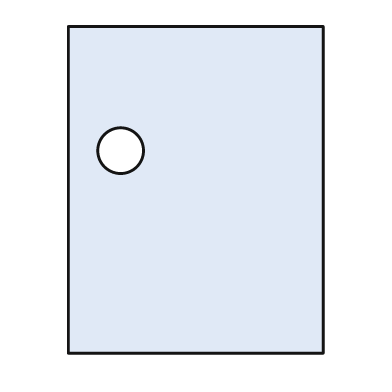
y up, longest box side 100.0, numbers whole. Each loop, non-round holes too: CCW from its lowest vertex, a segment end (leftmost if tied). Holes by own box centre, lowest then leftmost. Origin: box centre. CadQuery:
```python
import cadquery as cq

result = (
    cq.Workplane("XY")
    .moveTo(-39.0, -50.0)
    .lineTo(39.0, -50.0)
    .lineTo(39.0, 50.0)
    .lineTo(-39.0, 50.0)
    .close()
    .moveTo(-23.0, 12.0)
    .circle(7.0)
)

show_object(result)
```